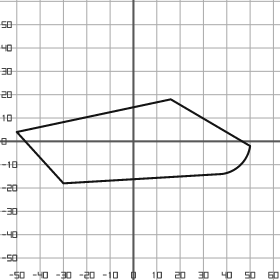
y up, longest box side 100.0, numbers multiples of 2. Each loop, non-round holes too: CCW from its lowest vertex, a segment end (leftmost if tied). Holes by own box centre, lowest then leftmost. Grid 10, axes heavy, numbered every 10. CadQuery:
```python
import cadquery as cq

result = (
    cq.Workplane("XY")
    .moveTo(-30.0, -18.0)
    .lineTo(38.0, -14.0)
    .threePointArc((46.0, -10.0), (50.0, -2.0))
    .lineTo(16.0, 18.0)
    .lineTo(-50.0, 4.0)
    .close()
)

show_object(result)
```